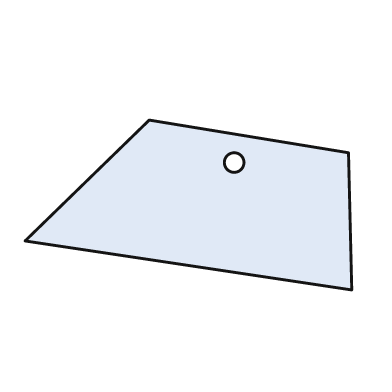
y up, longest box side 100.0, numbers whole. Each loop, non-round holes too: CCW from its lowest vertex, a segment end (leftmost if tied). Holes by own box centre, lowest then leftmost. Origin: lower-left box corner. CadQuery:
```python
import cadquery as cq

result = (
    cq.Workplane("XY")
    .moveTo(100.0, 0.0)
    .lineTo(99.0, 42.0)
    .lineTo(38.0, 52.0)
    .lineTo(0.0, 15.0)
    .close()
    .moveTo(64.0, 39.0)
    .circle(3.0)
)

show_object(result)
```